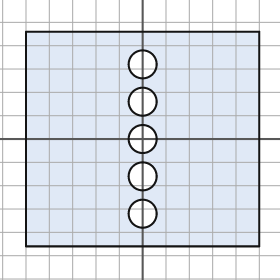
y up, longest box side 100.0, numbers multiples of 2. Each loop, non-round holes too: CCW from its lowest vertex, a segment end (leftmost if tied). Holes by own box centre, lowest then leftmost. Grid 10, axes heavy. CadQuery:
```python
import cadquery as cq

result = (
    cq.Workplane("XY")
    .moveTo(-50.0, -46.0)
    .lineTo(50.0, -46.0)
    .lineTo(50.0, 46.0)
    .lineTo(-50.0, 46.0)
    .close()
    .moveTo(0.0, -32.0)
    .circle(6.0)
    .moveTo(0.0, -16.0)
    .circle(6.0)
    .moveTo(0.0, 0.0)
    .circle(6.0)
    .moveTo(0.0, 16.0)
    .circle(6.0)
    .moveTo(0.0, 32.0)
    .circle(6.0)
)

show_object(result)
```